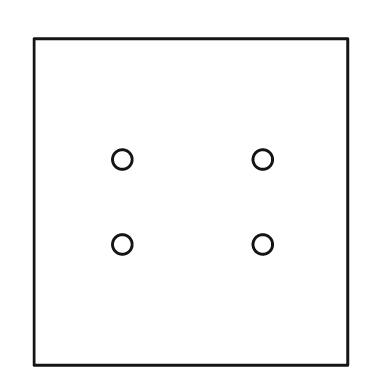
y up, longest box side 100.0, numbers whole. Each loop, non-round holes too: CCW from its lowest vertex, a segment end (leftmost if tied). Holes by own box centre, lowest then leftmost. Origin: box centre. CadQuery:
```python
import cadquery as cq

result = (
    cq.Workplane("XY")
    .moveTo(-48.0, -50.0)
    .lineTo(48.0, -50.0)
    .lineTo(48.0, 50.0)
    .lineTo(-48.0, 50.0)
    .close()
    .moveTo(-21.0, -13.0)
    .circle(3.0)
    .moveTo(22.0, -13.0)
    .circle(3.0)
    .moveTo(-21.0, 13.0)
    .circle(3.0)
    .moveTo(22.0, 13.0)
    .circle(3.0)
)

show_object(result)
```